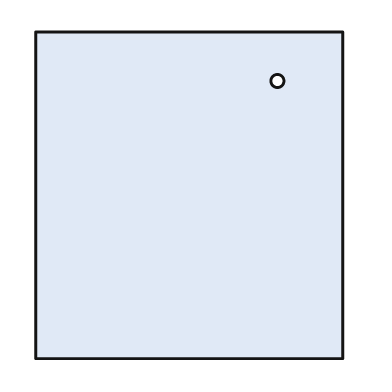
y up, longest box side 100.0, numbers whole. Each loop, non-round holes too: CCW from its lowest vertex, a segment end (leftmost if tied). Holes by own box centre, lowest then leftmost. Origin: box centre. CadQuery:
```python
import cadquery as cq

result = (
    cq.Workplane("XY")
    .moveTo(-47.0, -50.0)
    .lineTo(47.0, -50.0)
    .lineTo(47.0, 50.0)
    .lineTo(-47.0, 50.0)
    .close()
    .moveTo(27.0, 35.0)
    .circle(2.0)
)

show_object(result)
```